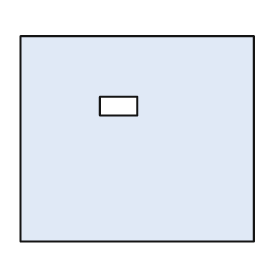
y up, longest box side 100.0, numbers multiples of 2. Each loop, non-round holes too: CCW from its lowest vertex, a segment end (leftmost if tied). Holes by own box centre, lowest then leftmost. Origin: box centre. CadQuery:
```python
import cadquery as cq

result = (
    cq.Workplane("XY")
    .moveTo(-50.0, -44.0)
    .lineTo(50.0, -44.0)
    .lineTo(50.0, 44.0)
    .lineTo(-50.0, 44.0)
    .close()
    .moveTo(-16.0, 10.0)
    .lineTo(0.0, 10.0)
    .lineTo(0.0, 18.0)
    .lineTo(-16.0, 18.0)
    .close()
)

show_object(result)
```